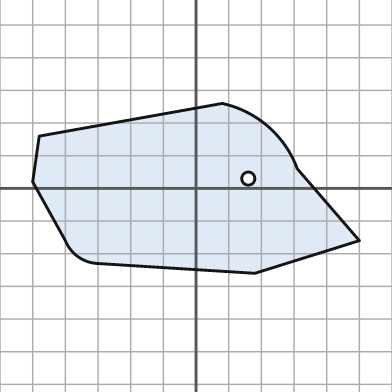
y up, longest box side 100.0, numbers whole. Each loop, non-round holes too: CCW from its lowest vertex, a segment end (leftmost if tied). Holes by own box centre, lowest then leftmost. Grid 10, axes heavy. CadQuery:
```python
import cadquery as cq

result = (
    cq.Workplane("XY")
    .moveTo(18.0, -26.0)
    .lineTo(50.0, -16.0)
    .lineTo(31.0, 6.0)
    .threePointArc((22.0, 19.0), (8.0, 26.0))
    .lineTo(-48.0, 16.0)
    .lineTo(-50.0, 2.0)
    .lineTo(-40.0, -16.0)
    .threePointArc((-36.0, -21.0), (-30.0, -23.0))
    .close()
    .moveTo(16.0, 3.0)
    .circle(2.0)
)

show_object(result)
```